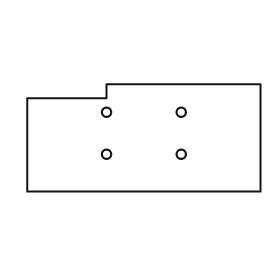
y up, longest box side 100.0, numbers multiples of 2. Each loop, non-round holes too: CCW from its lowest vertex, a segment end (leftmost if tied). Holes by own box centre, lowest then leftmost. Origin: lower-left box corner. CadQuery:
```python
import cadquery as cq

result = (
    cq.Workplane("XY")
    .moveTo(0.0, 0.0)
    .lineTo(100.0, 0.0)
    .lineTo(100.0, 46.0)
    .lineTo(34.0, 46.0)
    .lineTo(34.0, 40.0)
    .lineTo(0.0, 40.0)
    .close()
    .moveTo(34.0, 16.0)
    .circle(2.0)
    .moveTo(66.0, 16.0)
    .circle(2.0)
    .moveTo(34.0, 34.0)
    .circle(2.0)
    .moveTo(66.0, 34.0)
    .circle(2.0)
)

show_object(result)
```